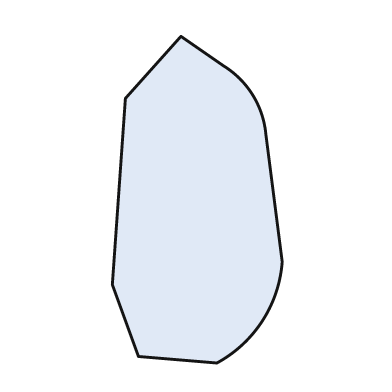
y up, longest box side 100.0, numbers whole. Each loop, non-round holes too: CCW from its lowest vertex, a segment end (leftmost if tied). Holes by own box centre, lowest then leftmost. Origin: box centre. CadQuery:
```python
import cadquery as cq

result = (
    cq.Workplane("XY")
    .moveTo(6.0, -50.0)
    .threePointArc((20.0, -37.0), (26.0, -19.0))
    .lineTo(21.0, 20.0)
    .threePointArc((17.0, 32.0), (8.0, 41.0))
    .lineTo(-5.0, 50.0)
    .lineTo(-22.0, 31.0)
    .lineTo(-26.0, -26.0)
    .lineTo(-18.0, -48.0)
    .close()
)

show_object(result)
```